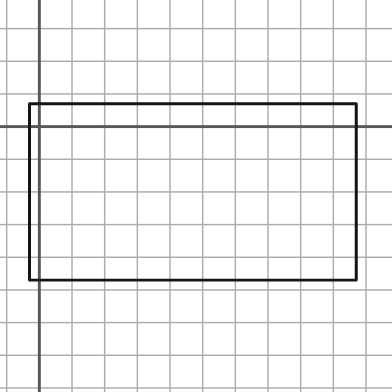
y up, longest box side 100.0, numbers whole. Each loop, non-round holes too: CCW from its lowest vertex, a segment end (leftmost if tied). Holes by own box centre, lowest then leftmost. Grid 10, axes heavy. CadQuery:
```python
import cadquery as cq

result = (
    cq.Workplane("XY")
    .moveTo(-3.0, -47.0)
    .lineTo(97.0, -47.0)
    .lineTo(97.0, 7.0)
    .lineTo(-3.0, 7.0)
    .close()
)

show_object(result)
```